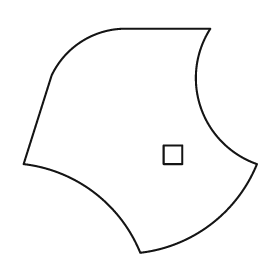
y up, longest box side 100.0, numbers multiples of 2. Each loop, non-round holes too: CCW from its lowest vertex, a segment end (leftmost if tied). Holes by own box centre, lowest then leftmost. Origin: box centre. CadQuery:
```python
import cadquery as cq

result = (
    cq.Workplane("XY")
    .moveTo(0.0, -48.0)
    .threePointArc((30.0, -36.0), (50.0, -10.0))
    .threePointArc((26.0, 14.0), (30.0, 48.0))
    .lineTo(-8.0, 48.0)
    .threePointArc((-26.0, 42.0), (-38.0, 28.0))
    .lineTo(-50.0, -10.0)
    .threePointArc((-20.0, -22.0), (0.0, -48.0))
    .close()
    .moveTo(10.0, -10.0)
    .lineTo(18.0, -10.0)
    .lineTo(18.0, -2.0)
    .lineTo(10.0, -2.0)
    .close()
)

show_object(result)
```